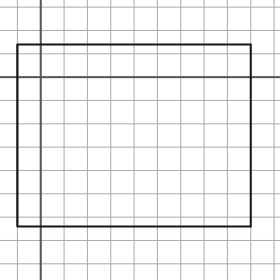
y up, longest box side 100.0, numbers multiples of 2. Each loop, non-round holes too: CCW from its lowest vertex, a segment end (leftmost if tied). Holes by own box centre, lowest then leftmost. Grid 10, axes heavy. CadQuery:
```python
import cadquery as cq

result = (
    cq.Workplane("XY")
    .moveTo(-10.0, -64.0)
    .lineTo(90.0, -64.0)
    .lineTo(90.0, 14.0)
    .lineTo(-10.0, 14.0)
    .close()
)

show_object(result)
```